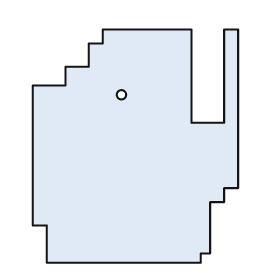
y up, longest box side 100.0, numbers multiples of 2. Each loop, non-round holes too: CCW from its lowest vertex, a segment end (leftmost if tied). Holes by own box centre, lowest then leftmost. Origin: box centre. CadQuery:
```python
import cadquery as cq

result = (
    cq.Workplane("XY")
    .moveTo(-38.0, -50.0)
    .lineTo(28.0, -50.0)
    .lineTo(28.0, -46.0)
    .lineTo(32.0, -46.0)
    .lineTo(32.0, -24.0)
    .lineTo(38.0, -24.0)
    .lineTo(38.0, -18.0)
    .lineTo(44.0, -18.0)
    .lineTo(44.0, 50.0)
    .lineTo(38.0, 50.0)
    .lineTo(38.0, 10.0)
    .lineTo(24.0, 10.0)
    .lineTo(24.0, 50.0)
    .lineTo(-14.0, 50.0)
    .lineTo(-14.0, 44.0)
    .lineTo(-20.0, 44.0)
    .lineTo(-20.0, 34.0)
    .lineTo(-30.0, 34.0)
    .lineTo(-30.0, 26.0)
    .lineTo(-44.0, 26.0)
    .lineTo(-44.0, -34.0)
    .lineTo(-38.0, -34.0)
    .close()
    .moveTo(-6.0, 22.0)
    .circle(2.0)
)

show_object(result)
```